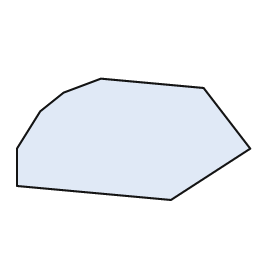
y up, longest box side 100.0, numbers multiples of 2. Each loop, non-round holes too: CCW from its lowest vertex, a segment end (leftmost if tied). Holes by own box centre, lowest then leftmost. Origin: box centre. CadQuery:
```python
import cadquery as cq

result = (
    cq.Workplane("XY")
    .moveTo(16.0, -26.0)
    .lineTo(50.0, -4.0)
    .lineTo(30.0, 22.0)
    .lineTo(-14.0, 26.0)
    .lineTo(-30.0, 20.0)
    .lineTo(-40.0, 12.0)
    .lineTo(-50.0, -4.0)
    .lineTo(-50.0, -20.0)
    .close()
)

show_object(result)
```